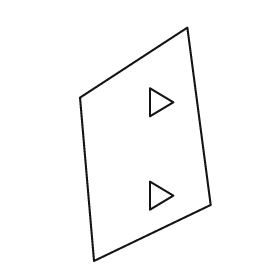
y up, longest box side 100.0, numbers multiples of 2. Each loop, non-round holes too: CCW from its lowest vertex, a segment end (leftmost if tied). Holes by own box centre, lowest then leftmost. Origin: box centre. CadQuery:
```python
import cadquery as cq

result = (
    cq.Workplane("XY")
    .moveTo(-22.0, -50.0)
    .lineTo(28.0, -26.0)
    .lineTo(18.0, 50.0)
    .lineTo(-28.0, 20.0)
    .close()
    .moveTo(2.0, -28.0)
    .lineTo(12.0, -22.0)
    .lineTo(2.0, -16.0)
    .close()
    .moveTo(2.0, 12.0)
    .lineTo(12.0, 18.0)
    .lineTo(2.0, 24.0)
    .close()
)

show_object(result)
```